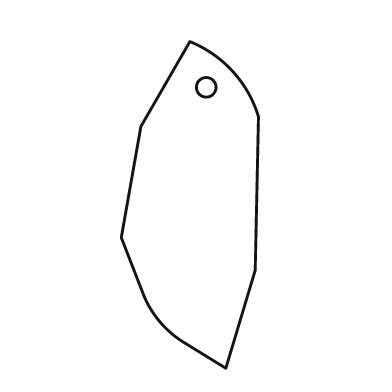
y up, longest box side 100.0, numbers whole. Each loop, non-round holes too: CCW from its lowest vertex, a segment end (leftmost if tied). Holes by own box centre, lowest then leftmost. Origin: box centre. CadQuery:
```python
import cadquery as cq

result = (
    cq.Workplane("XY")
    .moveTo(11.0, -50.0)
    .lineTo(20.0, -20.0)
    .lineTo(21.0, 27.0)
    .threePointArc((13.0, 41.0), (0.0, 50.0))
    .lineTo(-15.0, 24.0)
    .lineTo(-21.0, -10.0)
    .lineTo(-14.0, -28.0)
    .threePointArc((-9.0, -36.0), (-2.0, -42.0))
    .close()
    .moveTo(5.0, 36.0)
    .circle(3.0)
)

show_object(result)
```